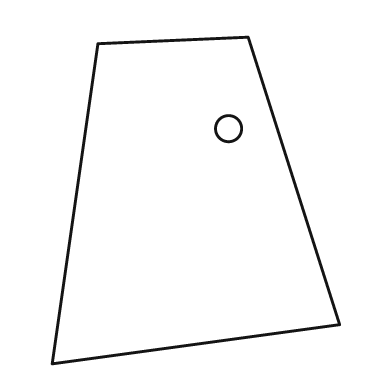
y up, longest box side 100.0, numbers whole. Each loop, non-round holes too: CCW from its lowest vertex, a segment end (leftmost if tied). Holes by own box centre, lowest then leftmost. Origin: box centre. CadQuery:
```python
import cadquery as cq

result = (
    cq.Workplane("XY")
    .moveTo(-44.0, -50.0)
    .lineTo(44.0, -38.0)
    .lineTo(16.0, 50.0)
    .lineTo(-30.0, 48.0)
    .close()
    .moveTo(10.0, 22.0)
    .circle(4.0)
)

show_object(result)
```